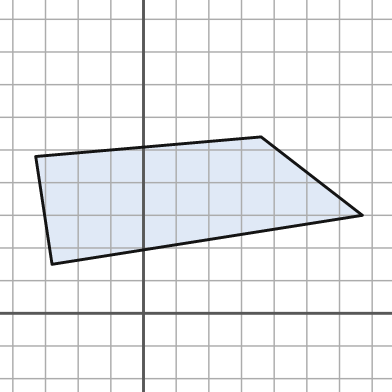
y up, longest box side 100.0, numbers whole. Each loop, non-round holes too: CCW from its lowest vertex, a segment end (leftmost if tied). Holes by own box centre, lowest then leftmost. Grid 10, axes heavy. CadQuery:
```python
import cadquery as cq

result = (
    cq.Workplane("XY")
    .moveTo(-28.0, 15.0)
    .lineTo(67.0, 30.0)
    .lineTo(36.0, 54.0)
    .lineTo(-33.0, 48.0)
    .close()
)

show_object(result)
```